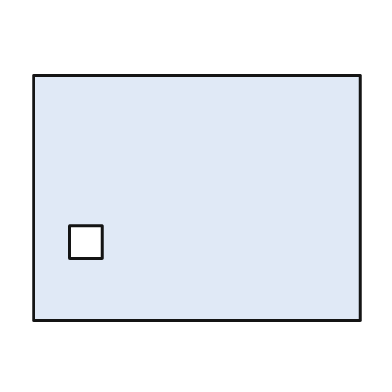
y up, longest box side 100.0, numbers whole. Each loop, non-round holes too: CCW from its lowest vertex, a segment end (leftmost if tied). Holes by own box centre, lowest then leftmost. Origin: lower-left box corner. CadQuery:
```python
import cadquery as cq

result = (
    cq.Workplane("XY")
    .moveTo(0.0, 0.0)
    .lineTo(100.0, 0.0)
    .lineTo(100.0, 75.0)
    .lineTo(0.0, 75.0)
    .close()
    .moveTo(11.0, 19.0)
    .lineTo(21.0, 19.0)
    .lineTo(21.0, 29.0)
    .lineTo(11.0, 29.0)
    .close()
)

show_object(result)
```